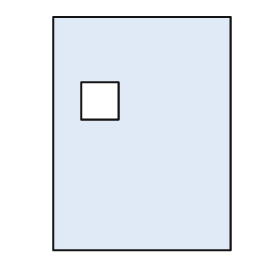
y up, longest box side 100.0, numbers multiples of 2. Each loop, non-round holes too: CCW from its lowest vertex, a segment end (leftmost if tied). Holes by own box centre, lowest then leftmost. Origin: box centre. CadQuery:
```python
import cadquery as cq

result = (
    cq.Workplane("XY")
    .moveTo(-38.0, -50.0)
    .lineTo(38.0, -50.0)
    .lineTo(38.0, 50.0)
    .lineTo(-38.0, 50.0)
    .close()
    .moveTo(-26.0, 6.0)
    .lineTo(-10.0, 6.0)
    .lineTo(-10.0, 22.0)
    .lineTo(-26.0, 22.0)
    .close()
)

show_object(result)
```